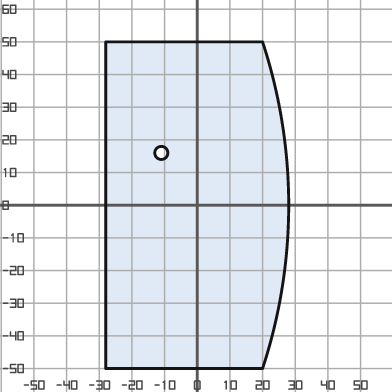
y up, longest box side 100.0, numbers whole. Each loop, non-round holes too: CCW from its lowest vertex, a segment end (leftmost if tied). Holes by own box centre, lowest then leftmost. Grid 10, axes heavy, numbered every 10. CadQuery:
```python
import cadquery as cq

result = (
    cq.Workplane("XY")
    .moveTo(-28.0, -50.0)
    .lineTo(20.0, -50.0)
    .threePointArc((28.0, 0.0), (20.0, 50.0))
    .lineTo(-28.0, 50.0)
    .close()
    .moveTo(-11.0, 16.0)
    .circle(2.0)
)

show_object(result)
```